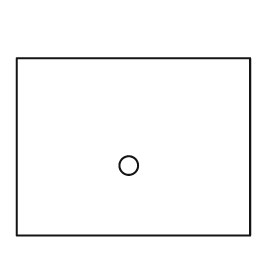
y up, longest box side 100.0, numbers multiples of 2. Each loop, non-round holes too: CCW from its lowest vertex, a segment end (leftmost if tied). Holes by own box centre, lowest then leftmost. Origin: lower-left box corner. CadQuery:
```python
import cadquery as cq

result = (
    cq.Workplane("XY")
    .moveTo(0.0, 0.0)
    .lineTo(100.0, 0.0)
    .lineTo(100.0, 76.0)
    .lineTo(0.0, 76.0)
    .close()
    .moveTo(48.0, 30.0)
    .circle(4.0)
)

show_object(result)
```